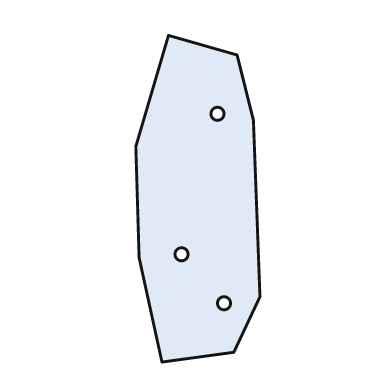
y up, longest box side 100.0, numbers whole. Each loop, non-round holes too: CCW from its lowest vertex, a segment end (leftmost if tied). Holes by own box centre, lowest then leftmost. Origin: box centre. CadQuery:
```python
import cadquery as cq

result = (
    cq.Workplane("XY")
    .moveTo(-11.0, -50.0)
    .lineTo(11.0, -47.0)
    .lineTo(19.0, -30.0)
    .lineTo(17.0, 24.0)
    .lineTo(12.0, 44.0)
    .lineTo(-9.0, 50.0)
    .lineTo(-19.0, 16.0)
    .lineTo(-18.0, -18.0)
    .close()
    .moveTo(8.0, -32.0)
    .circle(2.0)
    .moveTo(-5.0, -17.0)
    .circle(2.0)
    .moveTo(6.0, 26.0)
    .circle(2.0)
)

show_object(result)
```